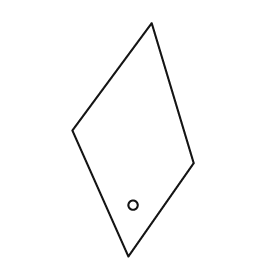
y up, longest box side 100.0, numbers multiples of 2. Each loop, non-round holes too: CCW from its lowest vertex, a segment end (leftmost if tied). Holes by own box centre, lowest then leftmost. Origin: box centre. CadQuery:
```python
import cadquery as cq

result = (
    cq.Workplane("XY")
    .moveTo(-2.0, -50.0)
    .lineTo(26.0, -10.0)
    .lineTo(8.0, 50.0)
    .lineTo(-26.0, 4.0)
    .close()
    .moveTo(0.0, -28.0)
    .circle(2.0)
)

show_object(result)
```